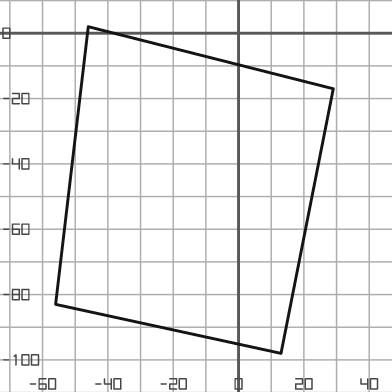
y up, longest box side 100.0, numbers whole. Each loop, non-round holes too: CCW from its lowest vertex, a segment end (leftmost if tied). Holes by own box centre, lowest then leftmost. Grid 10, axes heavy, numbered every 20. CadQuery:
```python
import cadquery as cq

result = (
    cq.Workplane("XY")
    .moveTo(13.0, -98.0)
    .lineTo(29.0, -17.0)
    .lineTo(-46.0, 2.0)
    .lineTo(-56.0, -83.0)
    .close()
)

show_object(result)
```